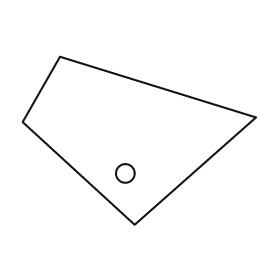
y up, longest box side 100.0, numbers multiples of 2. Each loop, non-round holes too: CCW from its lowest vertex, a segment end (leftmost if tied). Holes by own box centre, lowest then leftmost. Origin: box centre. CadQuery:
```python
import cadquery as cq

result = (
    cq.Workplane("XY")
    .moveTo(-2.0, -36.0)
    .lineTo(50.0, 10.0)
    .lineTo(-34.0, 36.0)
    .lineTo(-50.0, 8.0)
    .close()
    .moveTo(-6.0, -14.0)
    .circle(4.0)
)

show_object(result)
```